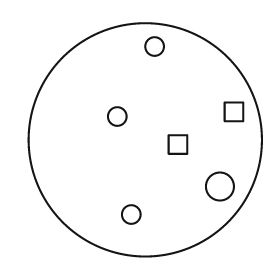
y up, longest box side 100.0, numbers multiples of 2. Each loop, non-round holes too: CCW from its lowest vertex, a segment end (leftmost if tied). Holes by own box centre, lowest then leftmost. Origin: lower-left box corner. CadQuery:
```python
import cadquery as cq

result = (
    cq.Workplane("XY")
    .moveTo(50.0, 50.0)
    .circle(50.0)
    .moveTo(44.0, 18.0)
    .circle(4.0)
    .moveTo(82.0, 30.0)
    .circle(6.0)
    .moveTo(60.0, 44.0)
    .lineTo(68.0, 44.0)
    .lineTo(68.0, 52.0)
    .lineTo(60.0, 52.0)
    .close()
    .moveTo(38.0, 60.0)
    .circle(4.0)
    .moveTo(84.0, 58.0)
    .lineTo(92.0, 58.0)
    .lineTo(92.0, 66.0)
    .lineTo(84.0, 66.0)
    .close()
    .moveTo(54.0, 90.0)
    .circle(4.0)
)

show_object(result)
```